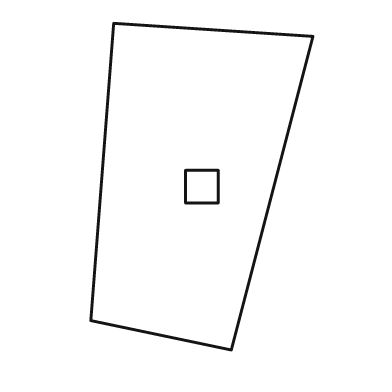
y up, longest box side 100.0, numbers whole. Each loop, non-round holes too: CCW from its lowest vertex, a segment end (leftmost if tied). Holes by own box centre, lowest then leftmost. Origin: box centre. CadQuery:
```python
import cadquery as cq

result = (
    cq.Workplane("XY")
    .moveTo(9.0, -50.0)
    .lineTo(34.0, 46.0)
    .lineTo(-27.0, 50.0)
    .lineTo(-34.0, -41.0)
    .close()
    .moveTo(-5.0, -5.0)
    .lineTo(5.0, -5.0)
    .lineTo(5.0, 5.0)
    .lineTo(-5.0, 5.0)
    .close()
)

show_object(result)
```